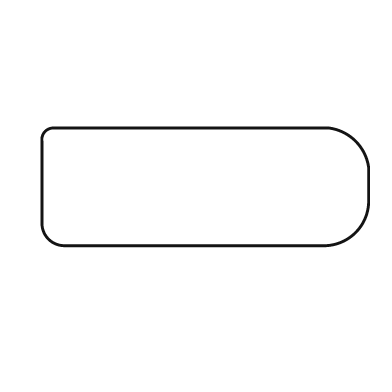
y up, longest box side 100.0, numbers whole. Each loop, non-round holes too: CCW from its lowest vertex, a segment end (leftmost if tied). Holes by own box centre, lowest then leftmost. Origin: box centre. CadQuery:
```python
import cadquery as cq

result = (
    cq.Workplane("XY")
    .moveTo(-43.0, -18.0)
    .lineTo(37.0, -18.0)
    .threePointArc((46.0, -14.0), (50.0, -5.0))
    .lineTo(50.0, 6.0)
    .threePointArc((46.0, 14.0), (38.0, 18.0))
    .lineTo(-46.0, 18.0)
    .threePointArc((-49.0, 17.0), (-50.0, 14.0))
    .lineTo(-50.0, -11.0)
    .threePointArc((-48.0, -16.0), (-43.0, -18.0))
    .close()
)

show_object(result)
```